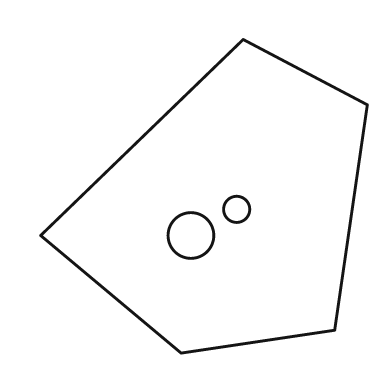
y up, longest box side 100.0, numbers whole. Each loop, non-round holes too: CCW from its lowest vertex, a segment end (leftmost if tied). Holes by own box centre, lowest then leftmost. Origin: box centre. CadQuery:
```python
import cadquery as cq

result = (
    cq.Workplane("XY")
    .moveTo(-7.0, -48.0)
    .lineTo(40.0, -41.0)
    .lineTo(50.0, 28.0)
    .lineTo(12.0, 48.0)
    .lineTo(-50.0, -12.0)
    .close()
    .moveTo(-4.0, -12.0)
    .circle(7.0)
    .moveTo(10.0, -4.0)
    .circle(4.0)
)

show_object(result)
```